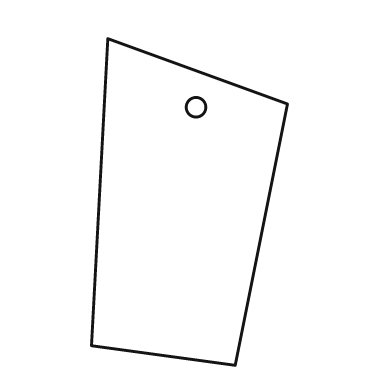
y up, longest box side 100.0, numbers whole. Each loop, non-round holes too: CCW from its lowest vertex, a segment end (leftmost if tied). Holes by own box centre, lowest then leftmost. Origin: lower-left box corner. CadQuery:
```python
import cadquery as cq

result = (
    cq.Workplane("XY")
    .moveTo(44.0, 0.0)
    .lineTo(60.0, 80.0)
    .lineTo(5.0, 100.0)
    .lineTo(0.0, 6.0)
    .close()
    .moveTo(32.0, 79.0)
    .circle(3.0)
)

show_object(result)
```